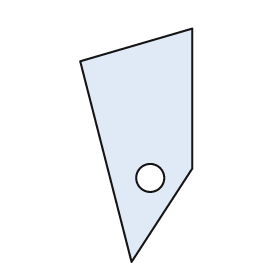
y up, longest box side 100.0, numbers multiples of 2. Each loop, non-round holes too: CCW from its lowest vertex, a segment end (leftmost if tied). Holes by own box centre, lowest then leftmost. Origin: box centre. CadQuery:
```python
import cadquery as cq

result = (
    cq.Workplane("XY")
    .moveTo(-2.0, -50.0)
    .lineTo(24.0, -10.0)
    .lineTo(24.0, 50.0)
    .lineTo(-24.0, 36.0)
    .close()
    .moveTo(6.0, -14.0)
    .circle(6.0)
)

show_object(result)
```